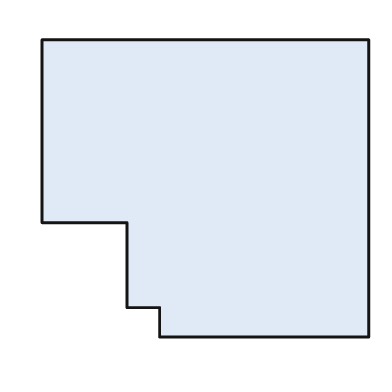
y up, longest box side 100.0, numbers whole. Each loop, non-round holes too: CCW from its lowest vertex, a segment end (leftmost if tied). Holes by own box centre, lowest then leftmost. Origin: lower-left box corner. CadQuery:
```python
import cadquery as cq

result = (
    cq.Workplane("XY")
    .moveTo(36.0, 0.0)
    .lineTo(100.0, 0.0)
    .lineTo(100.0, 91.0)
    .lineTo(0.0, 91.0)
    .lineTo(0.0, 35.0)
    .lineTo(26.0, 35.0)
    .lineTo(26.0, 9.0)
    .lineTo(36.0, 9.0)
    .close()
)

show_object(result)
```